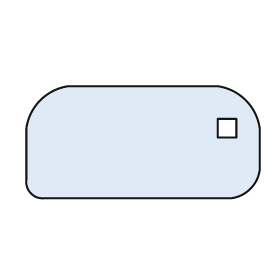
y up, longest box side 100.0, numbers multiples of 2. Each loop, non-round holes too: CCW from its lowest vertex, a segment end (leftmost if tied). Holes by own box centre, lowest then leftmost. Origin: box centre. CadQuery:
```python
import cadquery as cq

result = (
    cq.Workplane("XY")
    .moveTo(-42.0, -24.0)
    .lineTo(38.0, -24.0)
    .threePointArc((46.0, -20.0), (50.0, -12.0))
    .lineTo(50.0, 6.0)
    .threePointArc((44.0, 18.0), (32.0, 24.0))
    .lineTo(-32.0, 24.0)
    .threePointArc((-44.0, 18.0), (-50.0, 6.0))
    .lineTo(-50.0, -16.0)
    .threePointArc((-48.0, -22.0), (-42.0, -24.0))
    .close()
    .moveTo(32.0, 2.0)
    .lineTo(40.0, 2.0)
    .lineTo(40.0, 10.0)
    .lineTo(32.0, 10.0)
    .close()
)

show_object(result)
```